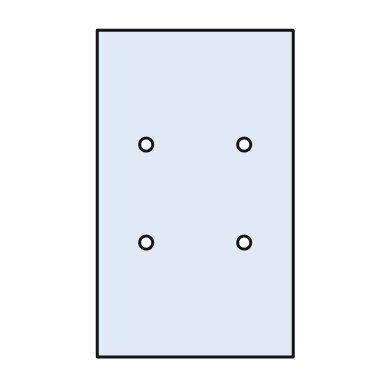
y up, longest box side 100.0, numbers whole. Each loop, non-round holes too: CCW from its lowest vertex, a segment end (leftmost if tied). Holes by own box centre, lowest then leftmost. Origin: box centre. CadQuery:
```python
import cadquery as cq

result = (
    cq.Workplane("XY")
    .moveTo(-30.0, -50.0)
    .lineTo(30.0, -50.0)
    .lineTo(30.0, 50.0)
    .lineTo(-30.0, 50.0)
    .close()
    .moveTo(-15.0, -15.0)
    .circle(2.0)
    .moveTo(15.0, -15.0)
    .circle(2.0)
    .moveTo(-15.0, 15.0)
    .circle(2.0)
    .moveTo(15.0, 15.0)
    .circle(2.0)
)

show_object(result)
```